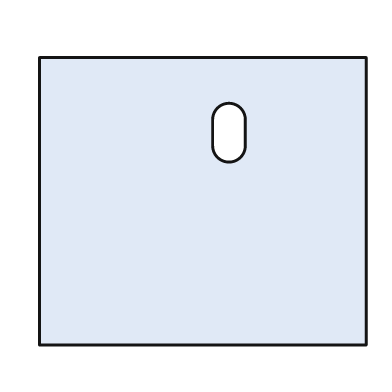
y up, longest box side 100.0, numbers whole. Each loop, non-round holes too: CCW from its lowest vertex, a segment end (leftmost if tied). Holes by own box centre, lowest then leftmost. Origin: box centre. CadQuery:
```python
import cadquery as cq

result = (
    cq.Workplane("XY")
    .moveTo(-50.0, -44.0)
    .lineTo(50.0, -44.0)
    .lineTo(50.0, 44.0)
    .lineTo(-50.0, 44.0)
    .close()
    .moveTo(3.0, 17.0)
    .threePointArc((8.0, 12.0), (13.0, 17.0))
    .lineTo(13.0, 25.0)
    .threePointArc((8.0, 30.0), (3.0, 25.0))
    .close()
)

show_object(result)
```